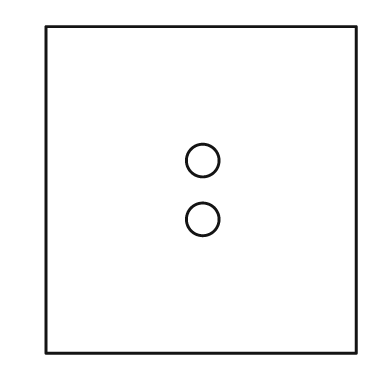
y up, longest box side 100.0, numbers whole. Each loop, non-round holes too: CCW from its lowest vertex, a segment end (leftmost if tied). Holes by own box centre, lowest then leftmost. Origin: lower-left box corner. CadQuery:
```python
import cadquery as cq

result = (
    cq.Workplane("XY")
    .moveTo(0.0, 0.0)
    .lineTo(95.0, 0.0)
    .lineTo(95.0, 100.0)
    .lineTo(0.0, 100.0)
    .close()
    .moveTo(48.0, 41.0)
    .circle(5.0)
    .moveTo(48.0, 59.0)
    .circle(5.0)
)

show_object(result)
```